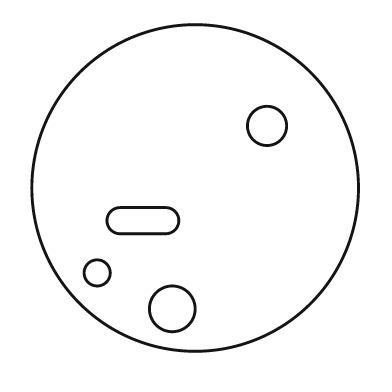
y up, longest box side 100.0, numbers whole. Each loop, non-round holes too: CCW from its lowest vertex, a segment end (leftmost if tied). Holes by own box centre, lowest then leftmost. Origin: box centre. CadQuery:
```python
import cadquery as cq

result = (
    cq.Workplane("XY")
    .moveTo(0.0, 0.0)
    .circle(50.0)
    .moveTo(-7.0, -37.0)
    .circle(7.0)
    .moveTo(-30.0, -26.0)
    .circle(4.0)
    .moveTo(-23.0, -14.0)
    .lineTo(-9.0, -14.0)
    .threePointArc((-5.0, -10.0), (-9.0, -6.0))
    .lineTo(-23.0, -6.0)
    .threePointArc((-27.0, -10.0), (-23.0, -14.0))
    .close()
    .moveTo(22.0, 19.0)
    .circle(6.0)
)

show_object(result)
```